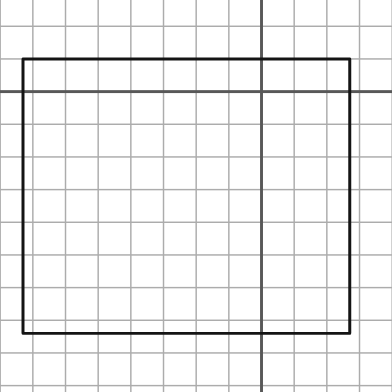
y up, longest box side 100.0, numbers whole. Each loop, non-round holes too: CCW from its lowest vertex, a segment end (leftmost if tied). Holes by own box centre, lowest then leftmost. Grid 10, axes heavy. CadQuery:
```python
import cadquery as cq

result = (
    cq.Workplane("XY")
    .moveTo(-73.0, -74.0)
    .lineTo(27.0, -74.0)
    .lineTo(27.0, 10.0)
    .lineTo(-73.0, 10.0)
    .close()
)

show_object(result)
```